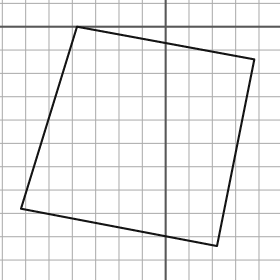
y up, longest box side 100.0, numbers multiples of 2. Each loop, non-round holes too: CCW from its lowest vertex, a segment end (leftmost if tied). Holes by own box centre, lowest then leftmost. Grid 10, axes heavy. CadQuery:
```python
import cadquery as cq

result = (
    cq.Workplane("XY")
    .moveTo(22.0, -94.0)
    .lineTo(38.0, -14.0)
    .lineTo(-38.0, 0.0)
    .lineTo(-62.0, -78.0)
    .close()
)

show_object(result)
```